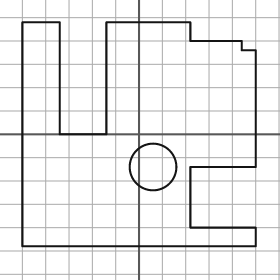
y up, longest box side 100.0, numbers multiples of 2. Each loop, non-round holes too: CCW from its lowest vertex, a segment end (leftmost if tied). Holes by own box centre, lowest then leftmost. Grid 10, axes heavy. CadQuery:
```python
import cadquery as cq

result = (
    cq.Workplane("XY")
    .moveTo(-50.0, -48.0)
    .lineTo(50.0, -48.0)
    .lineTo(50.0, -40.0)
    .lineTo(22.0, -40.0)
    .lineTo(22.0, -14.0)
    .lineTo(50.0, -14.0)
    .lineTo(50.0, 36.0)
    .lineTo(44.0, 36.0)
    .lineTo(44.0, 40.0)
    .lineTo(22.0, 40.0)
    .lineTo(22.0, 48.0)
    .lineTo(-14.0, 48.0)
    .lineTo(-14.0, 0.0)
    .lineTo(-34.0, 0.0)
    .lineTo(-34.0, 48.0)
    .lineTo(-50.0, 48.0)
    .close()
    .moveTo(6.0, -14.0)
    .circle(10.0)
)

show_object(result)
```